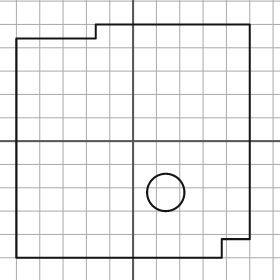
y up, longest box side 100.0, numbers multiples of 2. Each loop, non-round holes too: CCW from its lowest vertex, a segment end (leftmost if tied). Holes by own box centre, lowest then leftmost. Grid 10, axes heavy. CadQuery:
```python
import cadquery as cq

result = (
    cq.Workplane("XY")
    .moveTo(-50.0, -50.0)
    .lineTo(38.0, -50.0)
    .lineTo(38.0, -42.0)
    .lineTo(50.0, -42.0)
    .lineTo(50.0, 50.0)
    .lineTo(-16.0, 50.0)
    .lineTo(-16.0, 44.0)
    .lineTo(-50.0, 44.0)
    .close()
    .moveTo(14.0, -22.0)
    .circle(8.0)
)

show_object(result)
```